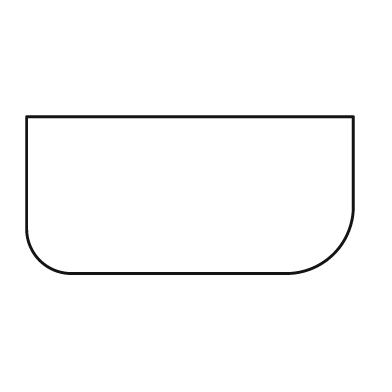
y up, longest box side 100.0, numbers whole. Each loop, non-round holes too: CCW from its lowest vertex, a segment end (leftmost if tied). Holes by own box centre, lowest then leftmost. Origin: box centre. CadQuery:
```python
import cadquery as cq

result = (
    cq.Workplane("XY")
    .moveTo(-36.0, -24.0)
    .lineTo(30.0, -24.0)
    .threePointArc((44.0, -18.0), (50.0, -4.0))
    .lineTo(50.0, 24.0)
    .lineTo(-50.0, 24.0)
    .lineTo(-50.0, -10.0)
    .threePointArc((-46.0, -20.0), (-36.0, -24.0))
    .close()
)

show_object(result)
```